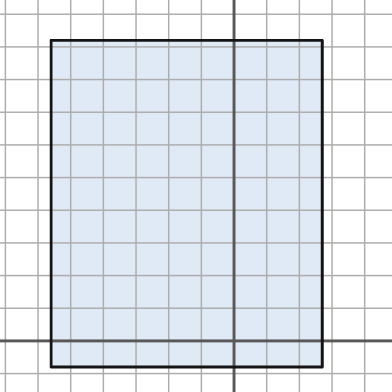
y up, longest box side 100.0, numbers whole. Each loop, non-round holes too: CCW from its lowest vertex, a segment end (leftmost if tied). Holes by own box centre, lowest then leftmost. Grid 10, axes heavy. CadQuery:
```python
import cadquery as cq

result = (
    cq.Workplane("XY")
    .moveTo(-56.0, -8.0)
    .lineTo(27.0, -8.0)
    .lineTo(27.0, 92.0)
    .lineTo(-56.0, 92.0)
    .close()
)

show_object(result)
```